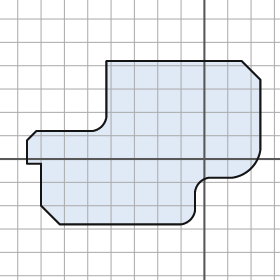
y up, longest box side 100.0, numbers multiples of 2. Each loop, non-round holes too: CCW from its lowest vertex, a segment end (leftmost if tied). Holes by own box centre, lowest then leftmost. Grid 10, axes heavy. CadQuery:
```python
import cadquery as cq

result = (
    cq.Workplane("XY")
    .moveTo(-62.0, -28.0)
    .lineTo(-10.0, -28.0)
    .threePointArc((-6.0, -26.0), (-4.0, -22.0))
    .lineTo(-4.0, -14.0)
    .threePointArc((-2.0, -10.0), (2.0, -8.0))
    .lineTo(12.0, -8.0)
    .threePointArc((20.0, -4.0), (24.0, 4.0))
    .lineTo(24.0, 34.0)
    .lineTo(16.0, 42.0)
    .lineTo(-42.0, 42.0)
    .lineTo(-42.0, 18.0)
    .threePointArc((-44.0, 14.0), (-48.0, 12.0))
    .lineTo(-72.0, 12.0)
    .lineTo(-76.0, 8.0)
    .lineTo(-76.0, -2.0)
    .lineTo(-70.0, -2.0)
    .lineTo(-70.0, -20.0)
    .close()
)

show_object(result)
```